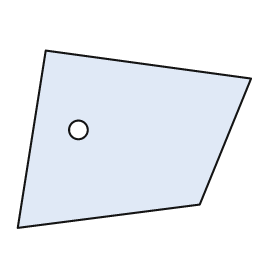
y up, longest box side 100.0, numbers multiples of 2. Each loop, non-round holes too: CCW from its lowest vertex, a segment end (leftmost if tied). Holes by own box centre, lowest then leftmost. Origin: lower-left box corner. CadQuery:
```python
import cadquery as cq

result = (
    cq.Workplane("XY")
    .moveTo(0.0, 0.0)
    .lineTo(78.0, 10.0)
    .lineTo(100.0, 64.0)
    .lineTo(12.0, 76.0)
    .close()
    .moveTo(26.0, 42.0)
    .circle(4.0)
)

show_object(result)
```